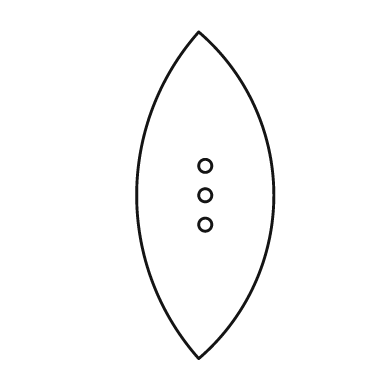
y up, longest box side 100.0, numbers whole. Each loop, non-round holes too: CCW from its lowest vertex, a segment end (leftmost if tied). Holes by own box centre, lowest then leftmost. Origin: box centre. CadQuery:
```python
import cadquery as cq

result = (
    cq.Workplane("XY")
    .moveTo(-2.0, -50.0)
    .threePointArc((21.0, 0.0), (-2.0, 50.0))
    .threePointArc((-21.0, 0.0), (-2.0, -50.0))
    .close()
    .moveTo(0.0, -9.0)
    .circle(2.0)
    .moveTo(0.0, 0.0)
    .circle(2.0)
    .moveTo(0.0, 9.0)
    .circle(2.0)
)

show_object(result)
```